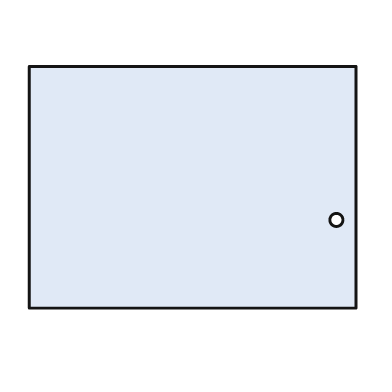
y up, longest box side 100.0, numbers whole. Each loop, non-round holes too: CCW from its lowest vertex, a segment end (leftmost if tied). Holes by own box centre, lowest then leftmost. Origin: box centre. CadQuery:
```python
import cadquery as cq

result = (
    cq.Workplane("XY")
    .moveTo(-50.0, -37.0)
    .lineTo(50.0, -37.0)
    .lineTo(50.0, 37.0)
    .lineTo(-50.0, 37.0)
    .close()
    .moveTo(44.0, -10.0)
    .circle(2.0)
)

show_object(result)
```